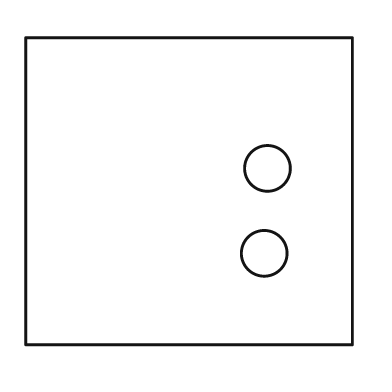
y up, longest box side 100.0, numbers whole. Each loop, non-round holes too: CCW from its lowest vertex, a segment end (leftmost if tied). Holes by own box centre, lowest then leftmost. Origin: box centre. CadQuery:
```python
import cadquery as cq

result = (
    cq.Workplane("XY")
    .moveTo(-50.0, -47.0)
    .lineTo(50.0, -47.0)
    .lineTo(50.0, 47.0)
    .lineTo(-50.0, 47.0)
    .close()
    .moveTo(23.0, -19.0)
    .circle(7.0)
    .moveTo(24.0, 7.0)
    .circle(7.0)
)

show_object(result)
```